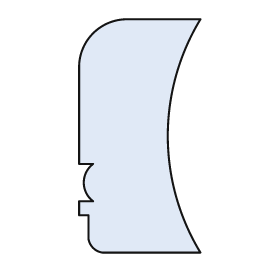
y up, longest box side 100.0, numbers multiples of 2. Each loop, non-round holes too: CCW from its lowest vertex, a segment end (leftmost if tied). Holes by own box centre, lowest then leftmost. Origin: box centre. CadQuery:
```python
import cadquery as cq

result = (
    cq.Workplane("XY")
    .moveTo(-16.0, -50.0)
    .lineTo(26.0, -50.0)
    .threePointArc((12.0, 0.0), (26.0, 50.0))
    .lineTo(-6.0, 50.0)
    .threePointArc((-20.0, 44.0), (-26.0, 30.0))
    .lineTo(-26.0, -12.0)
    .lineTo(-20.0, -12.0)
    .threePointArc((-24.0, -20.0), (-20.0, -28.0))
    .lineTo(-26.0, -28.0)
    .lineTo(-26.0, -34.0)
    .lineTo(-22.0, -34.0)
    .lineTo(-22.0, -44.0)
    .threePointArc((-20.0, -48.0), (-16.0, -50.0))
    .close()
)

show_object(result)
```